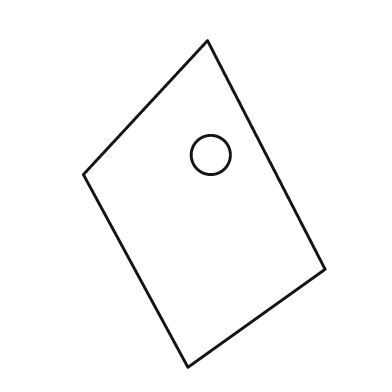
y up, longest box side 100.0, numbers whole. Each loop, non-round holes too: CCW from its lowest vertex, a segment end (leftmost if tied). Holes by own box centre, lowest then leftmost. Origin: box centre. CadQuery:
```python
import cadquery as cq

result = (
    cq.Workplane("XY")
    .moveTo(-5.0, -50.0)
    .lineTo(37.0, -20.0)
    .lineTo(1.0, 50.0)
    .lineTo(-37.0, 9.0)
    .close()
    .moveTo(2.0, 15.0)
    .circle(6.0)
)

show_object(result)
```